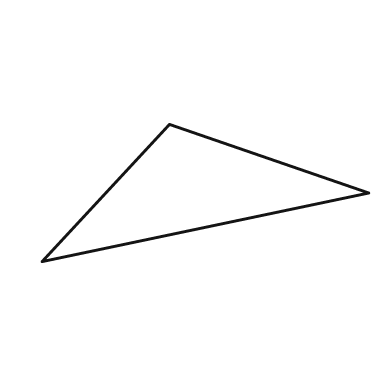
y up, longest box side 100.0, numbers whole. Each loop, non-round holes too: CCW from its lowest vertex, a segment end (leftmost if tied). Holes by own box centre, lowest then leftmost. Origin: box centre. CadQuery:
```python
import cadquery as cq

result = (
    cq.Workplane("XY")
    .moveTo(-50.0, -21.0)
    .lineTo(50.0, 0.0)
    .lineTo(-11.0, 21.0)
    .close()
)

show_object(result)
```